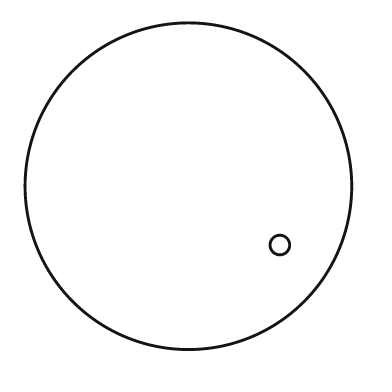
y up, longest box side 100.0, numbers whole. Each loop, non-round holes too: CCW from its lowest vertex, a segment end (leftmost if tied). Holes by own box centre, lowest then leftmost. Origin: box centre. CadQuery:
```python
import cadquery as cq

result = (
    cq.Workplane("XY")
    .moveTo(0.0, 0.0)
    .circle(50.0)
    .moveTo(28.0, -18.0)
    .circle(3.0)
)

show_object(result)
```